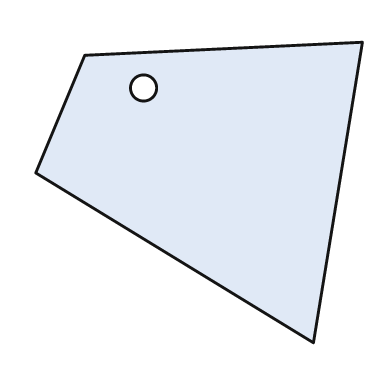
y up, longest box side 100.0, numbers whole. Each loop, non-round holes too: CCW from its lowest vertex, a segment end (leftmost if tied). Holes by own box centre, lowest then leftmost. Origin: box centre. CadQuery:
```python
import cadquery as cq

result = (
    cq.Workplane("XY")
    .moveTo(35.0, -46.0)
    .lineTo(50.0, 46.0)
    .lineTo(-35.0, 42.0)
    .lineTo(-50.0, 6.0)
    .close()
    .moveTo(-17.0, 32.0)
    .circle(4.0)
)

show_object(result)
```